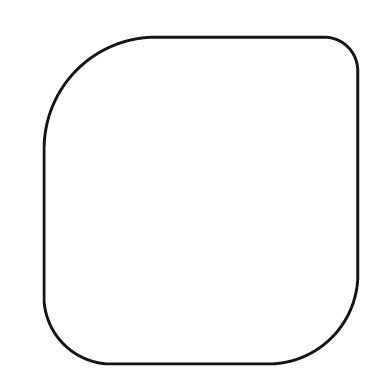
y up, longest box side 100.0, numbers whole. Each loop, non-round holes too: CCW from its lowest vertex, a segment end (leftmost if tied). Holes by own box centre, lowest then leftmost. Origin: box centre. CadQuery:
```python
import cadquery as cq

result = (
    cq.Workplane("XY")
    .moveTo(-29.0, -50.0)
    .lineTo(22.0, -50.0)
    .threePointArc((40.0, -42.0), (48.0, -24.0))
    .lineTo(48.0, 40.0)
    .threePointArc((45.0, 47.0), (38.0, 50.0))
    .lineTo(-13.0, 50.0)
    .threePointArc((-38.0, 40.0), (-48.0, 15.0))
    .lineTo(-48.0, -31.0)
    .threePointArc((-42.0, -44.0), (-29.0, -50.0))
    .close()
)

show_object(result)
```